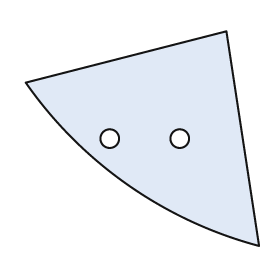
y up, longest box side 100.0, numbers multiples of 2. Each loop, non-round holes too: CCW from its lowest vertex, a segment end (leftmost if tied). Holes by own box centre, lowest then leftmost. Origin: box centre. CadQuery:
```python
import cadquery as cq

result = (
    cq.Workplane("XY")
    .moveTo(50.0, -46.0)
    .lineTo(36.0, 46.0)
    .lineTo(-50.0, 24.0)
    .threePointArc((-6.0, -20.0), (50.0, -46.0))
    .close()
    .moveTo(-14.0, 0.0)
    .circle(4.0)
    .moveTo(16.0, 0.0)
    .circle(4.0)
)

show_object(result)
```